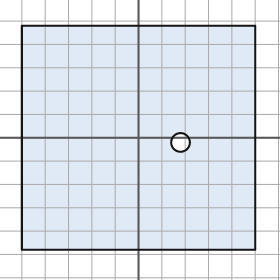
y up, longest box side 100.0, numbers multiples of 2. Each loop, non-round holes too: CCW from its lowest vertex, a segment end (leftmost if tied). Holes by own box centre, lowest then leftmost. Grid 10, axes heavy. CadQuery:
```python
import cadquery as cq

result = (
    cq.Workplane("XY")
    .moveTo(-50.0, -48.0)
    .lineTo(50.0, -48.0)
    .lineTo(50.0, 48.0)
    .lineTo(-50.0, 48.0)
    .close()
    .moveTo(18.0, -2.0)
    .circle(4.0)
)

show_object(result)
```